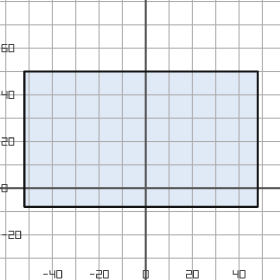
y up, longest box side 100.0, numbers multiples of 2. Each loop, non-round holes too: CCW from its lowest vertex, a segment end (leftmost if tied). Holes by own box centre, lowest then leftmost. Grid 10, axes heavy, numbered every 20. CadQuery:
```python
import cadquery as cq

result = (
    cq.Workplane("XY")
    .moveTo(-52.0, -8.0)
    .lineTo(48.0, -8.0)
    .lineTo(48.0, 50.0)
    .lineTo(-52.0, 50.0)
    .close()
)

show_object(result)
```